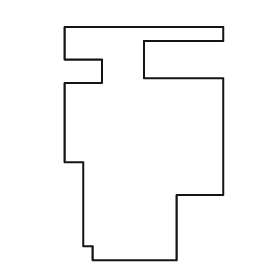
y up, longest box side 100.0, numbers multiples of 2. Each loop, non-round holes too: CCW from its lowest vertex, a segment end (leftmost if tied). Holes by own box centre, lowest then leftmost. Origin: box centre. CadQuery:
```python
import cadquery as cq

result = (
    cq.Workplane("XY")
    .moveTo(-22.0, -50.0)
    .lineTo(14.0, -50.0)
    .lineTo(14.0, -22.0)
    .lineTo(34.0, -22.0)
    .lineTo(34.0, 28.0)
    .lineTo(0.0, 28.0)
    .lineTo(0.0, 44.0)
    .lineTo(34.0, 44.0)
    .lineTo(34.0, 50.0)
    .lineTo(-34.0, 50.0)
    .lineTo(-34.0, 36.0)
    .lineTo(-18.0, 36.0)
    .lineTo(-18.0, 26.0)
    .lineTo(-34.0, 26.0)
    .lineTo(-34.0, -8.0)
    .lineTo(-26.0, -8.0)
    .lineTo(-26.0, -44.0)
    .lineTo(-22.0, -44.0)
    .close()
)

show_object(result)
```